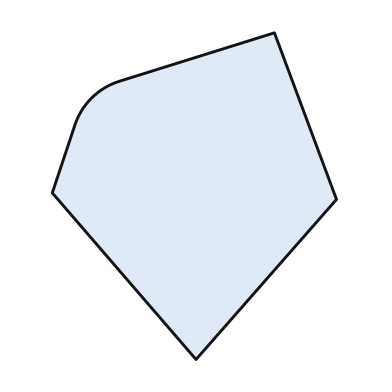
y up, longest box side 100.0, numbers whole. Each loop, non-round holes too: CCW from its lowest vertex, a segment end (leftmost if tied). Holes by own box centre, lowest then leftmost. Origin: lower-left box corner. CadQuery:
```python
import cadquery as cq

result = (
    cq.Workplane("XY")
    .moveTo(44.0, 0.0)
    .lineTo(87.0, 49.0)
    .lineTo(68.0, 100.0)
    .lineTo(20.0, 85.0)
    .threePointArc((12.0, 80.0), (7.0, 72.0))
    .lineTo(0.0, 51.0)
    .close()
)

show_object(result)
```